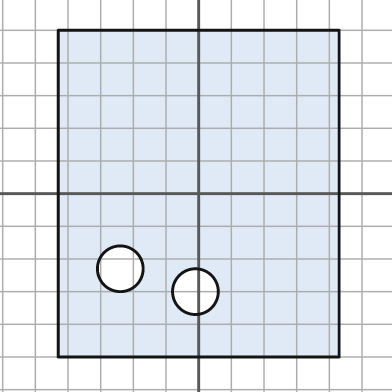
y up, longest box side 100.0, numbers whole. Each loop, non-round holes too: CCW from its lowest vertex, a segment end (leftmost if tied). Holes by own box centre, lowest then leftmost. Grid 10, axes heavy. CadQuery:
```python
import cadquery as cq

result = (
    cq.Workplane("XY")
    .moveTo(-43.0, -50.0)
    .lineTo(43.0, -50.0)
    .lineTo(43.0, 50.0)
    .lineTo(-43.0, 50.0)
    .close()
    .moveTo(-1.0, -30.0)
    .circle(7.0)
    .moveTo(-24.0, -23.0)
    .circle(7.0)
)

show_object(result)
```